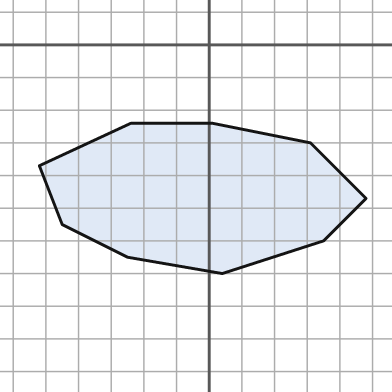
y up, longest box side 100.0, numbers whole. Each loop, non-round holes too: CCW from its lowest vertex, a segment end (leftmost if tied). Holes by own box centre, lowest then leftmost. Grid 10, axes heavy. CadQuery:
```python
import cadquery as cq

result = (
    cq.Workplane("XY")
    .moveTo(4.0, -70.0)
    .lineTo(35.0, -60.0)
    .lineTo(48.0, -47.0)
    .lineTo(31.0, -30.0)
    .lineTo(1.0, -24.0)
    .lineTo(-24.0, -24.0)
    .lineTo(-52.0, -37.0)
    .lineTo(-45.0, -55.0)
    .lineTo(-25.0, -65.0)
    .close()
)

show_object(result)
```